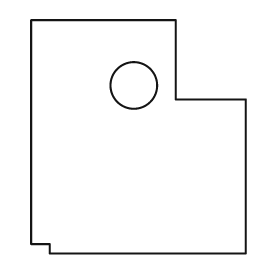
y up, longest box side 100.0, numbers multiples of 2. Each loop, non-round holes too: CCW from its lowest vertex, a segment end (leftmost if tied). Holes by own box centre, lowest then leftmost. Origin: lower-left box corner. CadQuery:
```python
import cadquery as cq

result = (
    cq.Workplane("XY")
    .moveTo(8.0, 0.0)
    .lineTo(92.0, 0.0)
    .lineTo(92.0, 66.0)
    .lineTo(62.0, 66.0)
    .lineTo(62.0, 100.0)
    .lineTo(0.0, 100.0)
    .lineTo(0.0, 4.0)
    .lineTo(8.0, 4.0)
    .close()
    .moveTo(44.0, 72.0)
    .circle(10.0)
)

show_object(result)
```